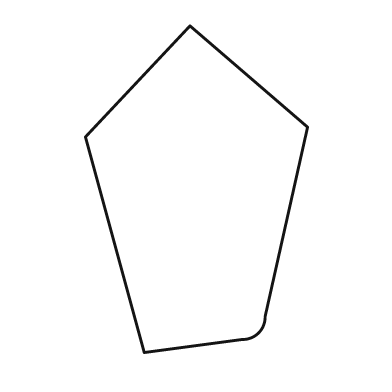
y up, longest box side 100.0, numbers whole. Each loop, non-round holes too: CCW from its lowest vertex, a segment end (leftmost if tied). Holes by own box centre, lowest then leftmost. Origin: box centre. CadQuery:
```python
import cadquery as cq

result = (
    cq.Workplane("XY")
    .moveTo(-16.0, -50.0)
    .lineTo(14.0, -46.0)
    .threePointArc((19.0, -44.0), (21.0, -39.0))
    .lineTo(34.0, 19.0)
    .lineTo(-2.0, 50.0)
    .lineTo(-34.0, 16.0)
    .close()
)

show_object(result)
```